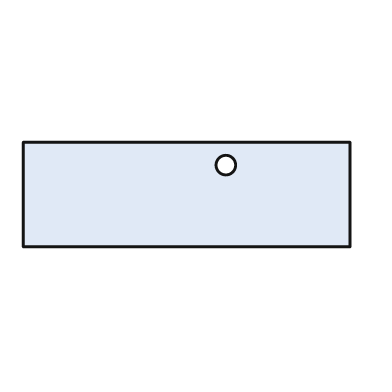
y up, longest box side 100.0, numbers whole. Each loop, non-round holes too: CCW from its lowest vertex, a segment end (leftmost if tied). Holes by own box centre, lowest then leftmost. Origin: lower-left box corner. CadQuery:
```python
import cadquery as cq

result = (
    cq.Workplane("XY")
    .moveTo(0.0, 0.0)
    .lineTo(100.0, 0.0)
    .lineTo(100.0, 32.0)
    .lineTo(0.0, 32.0)
    .close()
    .moveTo(62.0, 25.0)
    .circle(3.0)
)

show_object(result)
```